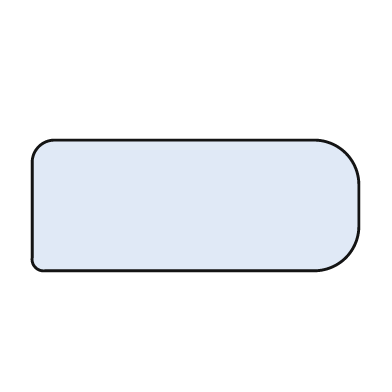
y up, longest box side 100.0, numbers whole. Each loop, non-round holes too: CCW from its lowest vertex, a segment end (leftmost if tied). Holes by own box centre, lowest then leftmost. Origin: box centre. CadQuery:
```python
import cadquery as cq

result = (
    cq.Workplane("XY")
    .moveTo(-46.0, -20.0)
    .lineTo(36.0, -20.0)
    .threePointArc((46.0, -16.0), (50.0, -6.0))
    .lineTo(50.0, 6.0)
    .threePointArc((46.0, 16.0), (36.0, 20.0))
    .lineTo(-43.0, 20.0)
    .threePointArc((-48.0, 18.0), (-50.0, 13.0))
    .lineTo(-50.0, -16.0)
    .threePointArc((-49.0, -19.0), (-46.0, -20.0))
    .close()
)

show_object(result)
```